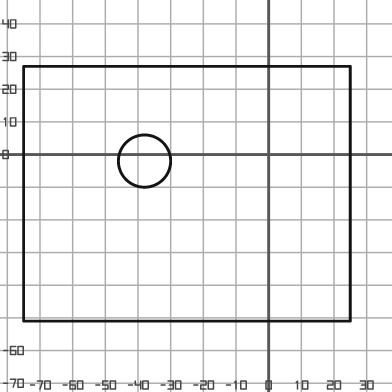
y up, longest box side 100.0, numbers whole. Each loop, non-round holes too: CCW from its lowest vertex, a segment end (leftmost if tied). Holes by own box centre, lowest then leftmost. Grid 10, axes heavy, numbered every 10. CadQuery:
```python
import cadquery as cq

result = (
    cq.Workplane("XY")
    .moveTo(-75.0, -51.0)
    .lineTo(25.0, -51.0)
    .lineTo(25.0, 27.0)
    .lineTo(-75.0, 27.0)
    .close()
    .moveTo(-38.0, -2.0)
    .circle(8.0)
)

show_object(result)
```